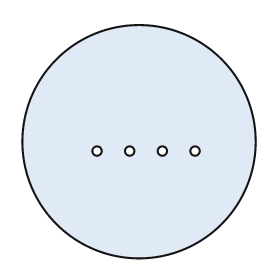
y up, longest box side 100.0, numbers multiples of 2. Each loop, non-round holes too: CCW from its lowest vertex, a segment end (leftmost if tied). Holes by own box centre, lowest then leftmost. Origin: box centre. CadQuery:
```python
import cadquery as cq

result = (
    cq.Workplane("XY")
    .moveTo(0.0, 0.0)
    .circle(50.0)
    .moveTo(-18.0, -4.0)
    .circle(2.0)
    .moveTo(-4.0, -4.0)
    .circle(2.0)
    .moveTo(10.0, -4.0)
    .circle(2.0)
    .moveTo(24.0, -4.0)
    .circle(2.0)
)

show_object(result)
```